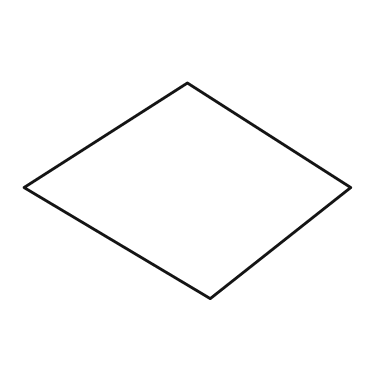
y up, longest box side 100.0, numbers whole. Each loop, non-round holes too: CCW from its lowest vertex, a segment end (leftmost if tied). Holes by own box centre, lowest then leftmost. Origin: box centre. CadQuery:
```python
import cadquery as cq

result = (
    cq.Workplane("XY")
    .moveTo(7.0, -33.0)
    .lineTo(50.0, 1.0)
    .lineTo(0.0, 33.0)
    .lineTo(-50.0, 1.0)
    .close()
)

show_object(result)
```